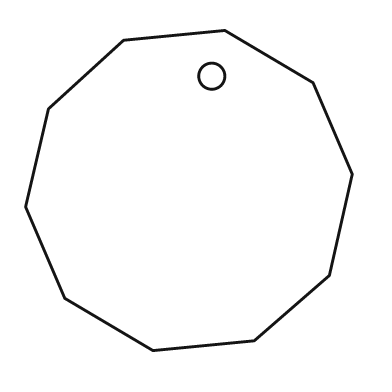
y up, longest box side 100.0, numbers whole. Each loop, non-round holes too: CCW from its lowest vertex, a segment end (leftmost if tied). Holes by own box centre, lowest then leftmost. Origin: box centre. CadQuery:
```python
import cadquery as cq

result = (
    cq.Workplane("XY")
    .moveTo(-11.0, -49.0)
    .lineTo(20.0, -46.0)
    .lineTo(43.0, -26.0)
    .lineTo(50.0, 5.0)
    .lineTo(38.0, 33.0)
    .lineTo(11.0, 49.0)
    .lineTo(-20.0, 46.0)
    .lineTo(-43.0, 25.0)
    .lineTo(-50.0, -5.0)
    .lineTo(-38.0, -33.0)
    .close()
    .moveTo(7.0, 35.0)
    .circle(4.0)
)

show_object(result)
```